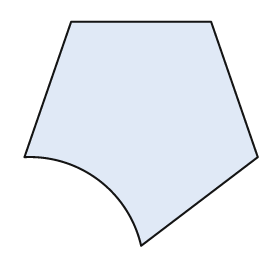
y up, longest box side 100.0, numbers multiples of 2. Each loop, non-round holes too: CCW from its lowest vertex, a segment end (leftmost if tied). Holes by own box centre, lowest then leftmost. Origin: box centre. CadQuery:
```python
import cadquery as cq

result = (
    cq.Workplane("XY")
    .moveTo(0.0, -48.0)
    .lineTo(50.0, -10.0)
    .lineTo(30.0, 48.0)
    .lineTo(-30.0, 48.0)
    .lineTo(-50.0, -10.0)
    .threePointArc((-18.0, -20.0), (0.0, -48.0))
    .close()
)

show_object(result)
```